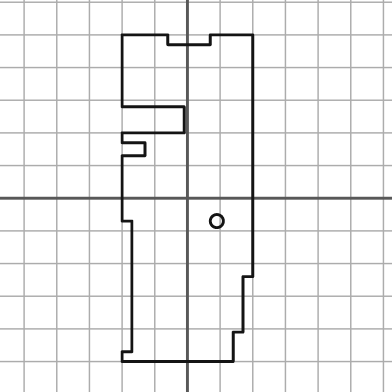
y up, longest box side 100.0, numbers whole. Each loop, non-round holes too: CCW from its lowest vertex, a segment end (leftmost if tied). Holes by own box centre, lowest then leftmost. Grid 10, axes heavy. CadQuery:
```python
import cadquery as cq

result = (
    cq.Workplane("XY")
    .moveTo(-20.0, -50.0)
    .lineTo(14.0, -50.0)
    .lineTo(14.0, -41.0)
    .lineTo(17.0, -41.0)
    .lineTo(17.0, -24.0)
    .lineTo(20.0, -24.0)
    .lineTo(20.0, 50.0)
    .lineTo(7.0, 50.0)
    .lineTo(7.0, 47.0)
    .lineTo(-6.0, 47.0)
    .lineTo(-6.0, 50.0)
    .lineTo(-20.0, 50.0)
    .lineTo(-20.0, 28.0)
    .lineTo(-1.0, 28.0)
    .lineTo(-1.0, 20.0)
    .lineTo(-20.0, 20.0)
    .lineTo(-20.0, 17.0)
    .lineTo(-13.0, 17.0)
    .lineTo(-13.0, 13.0)
    .lineTo(-20.0, 13.0)
    .lineTo(-20.0, -7.0)
    .lineTo(-17.0, -7.0)
    .lineTo(-17.0, -47.0)
    .lineTo(-20.0, -47.0)
    .close()
    .moveTo(9.0, -7.0)
    .circle(2.0)
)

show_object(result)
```